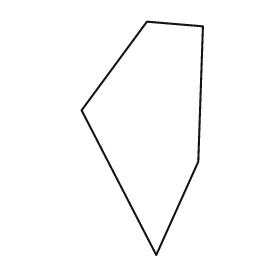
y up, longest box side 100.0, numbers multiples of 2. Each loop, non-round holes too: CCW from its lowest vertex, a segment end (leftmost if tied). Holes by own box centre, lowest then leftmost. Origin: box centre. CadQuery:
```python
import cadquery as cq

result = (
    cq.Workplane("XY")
    .moveTo(6.0, -50.0)
    .lineTo(24.0, -10.0)
    .lineTo(26.0, 48.0)
    .lineTo(2.0, 50.0)
    .lineTo(-26.0, 12.0)
    .close()
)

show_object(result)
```